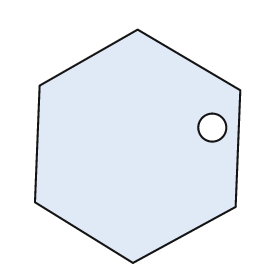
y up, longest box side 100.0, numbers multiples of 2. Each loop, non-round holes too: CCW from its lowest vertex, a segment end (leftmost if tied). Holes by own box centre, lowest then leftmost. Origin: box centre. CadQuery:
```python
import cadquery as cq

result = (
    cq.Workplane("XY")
    .moveTo(-2.0, -50.0)
    .lineTo(42.0, -26.0)
    .lineTo(44.0, 24.0)
    .lineTo(0.0, 50.0)
    .lineTo(-42.0, 26.0)
    .lineTo(-44.0, -24.0)
    .close()
    .moveTo(32.0, 8.0)
    .circle(6.0)
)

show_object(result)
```